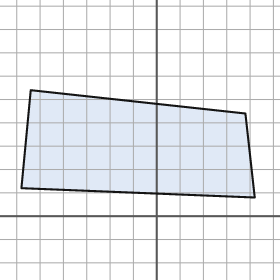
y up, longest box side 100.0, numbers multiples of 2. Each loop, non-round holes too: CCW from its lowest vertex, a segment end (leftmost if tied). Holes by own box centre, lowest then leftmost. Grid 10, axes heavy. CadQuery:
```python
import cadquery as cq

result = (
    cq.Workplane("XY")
    .moveTo(42.0, 8.0)
    .lineTo(38.0, 44.0)
    .lineTo(-54.0, 54.0)
    .lineTo(-58.0, 12.0)
    .close()
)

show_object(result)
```